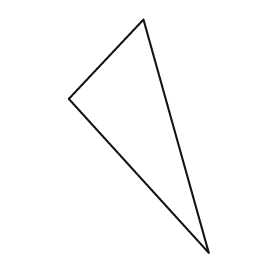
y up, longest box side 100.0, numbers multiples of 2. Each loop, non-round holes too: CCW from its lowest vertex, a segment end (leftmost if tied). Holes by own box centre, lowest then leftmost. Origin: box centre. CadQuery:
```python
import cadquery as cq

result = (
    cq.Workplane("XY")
    .moveTo(30.0, -50.0)
    .lineTo(2.0, 50.0)
    .lineTo(-30.0, 16.0)
    .close()
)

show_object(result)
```